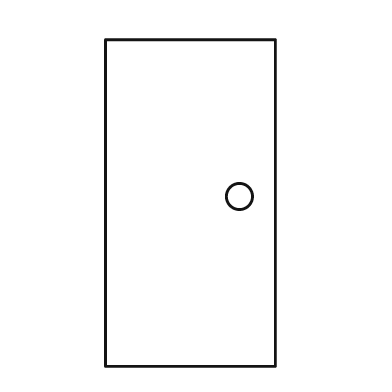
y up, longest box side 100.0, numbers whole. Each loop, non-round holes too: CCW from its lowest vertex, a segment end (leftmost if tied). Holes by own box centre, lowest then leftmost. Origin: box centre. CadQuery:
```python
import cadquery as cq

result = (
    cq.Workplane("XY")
    .moveTo(-26.0, -50.0)
    .lineTo(26.0, -50.0)
    .lineTo(26.0, 50.0)
    .lineTo(-26.0, 50.0)
    .close()
    .moveTo(15.0, 2.0)
    .circle(4.0)
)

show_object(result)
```